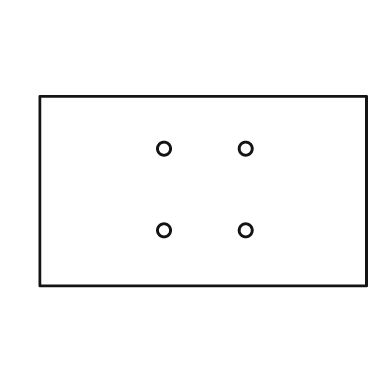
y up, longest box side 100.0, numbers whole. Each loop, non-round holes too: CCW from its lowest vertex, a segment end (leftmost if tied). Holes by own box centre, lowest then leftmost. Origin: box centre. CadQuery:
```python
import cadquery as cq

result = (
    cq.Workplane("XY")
    .moveTo(-50.0, -29.0)
    .lineTo(50.0, -29.0)
    .lineTo(50.0, 29.0)
    .lineTo(-50.0, 29.0)
    .close()
    .moveTo(-12.0, -12.0)
    .circle(2.0)
    .moveTo(13.0, -12.0)
    .circle(2.0)
    .moveTo(-12.0, 13.0)
    .circle(2.0)
    .moveTo(13.0, 13.0)
    .circle(2.0)
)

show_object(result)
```